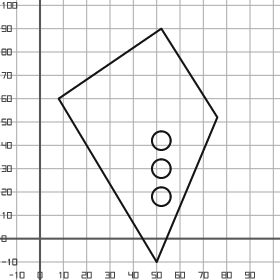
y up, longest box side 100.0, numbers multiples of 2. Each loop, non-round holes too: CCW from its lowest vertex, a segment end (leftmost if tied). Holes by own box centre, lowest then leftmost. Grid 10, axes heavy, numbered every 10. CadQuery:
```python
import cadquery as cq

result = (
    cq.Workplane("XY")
    .moveTo(50.0, -10.0)
    .lineTo(76.0, 52.0)
    .lineTo(52.0, 90.0)
    .lineTo(8.0, 60.0)
    .close()
    .moveTo(52.0, 18.0)
    .circle(4.0)
    .moveTo(52.0, 30.0)
    .circle(4.0)
    .moveTo(52.0, 42.0)
    .circle(4.0)
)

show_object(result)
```